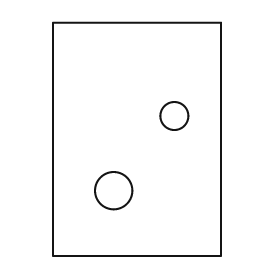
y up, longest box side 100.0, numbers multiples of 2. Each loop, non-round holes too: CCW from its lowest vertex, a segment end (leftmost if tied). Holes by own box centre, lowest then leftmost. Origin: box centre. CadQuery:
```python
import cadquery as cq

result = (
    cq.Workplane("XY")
    .moveTo(-36.0, -50.0)
    .lineTo(36.0, -50.0)
    .lineTo(36.0, 50.0)
    .lineTo(-36.0, 50.0)
    .close()
    .moveTo(-10.0, -22.0)
    .circle(8.0)
    .moveTo(16.0, 10.0)
    .circle(6.0)
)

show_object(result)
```